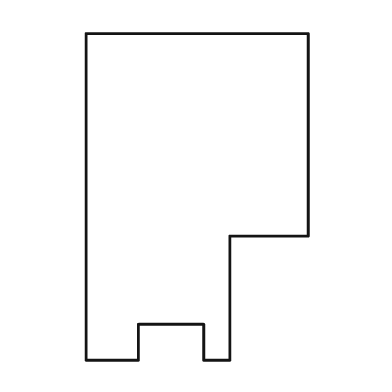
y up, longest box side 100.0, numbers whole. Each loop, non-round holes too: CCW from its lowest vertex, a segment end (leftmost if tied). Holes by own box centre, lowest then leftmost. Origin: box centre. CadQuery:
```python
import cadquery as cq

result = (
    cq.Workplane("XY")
    .moveTo(-34.0, -50.0)
    .lineTo(-18.0, -50.0)
    .lineTo(-18.0, -39.0)
    .lineTo(2.0, -39.0)
    .lineTo(2.0, -50.0)
    .lineTo(10.0, -50.0)
    .lineTo(10.0, -12.0)
    .lineTo(34.0, -12.0)
    .lineTo(34.0, 50.0)
    .lineTo(-34.0, 50.0)
    .close()
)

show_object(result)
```